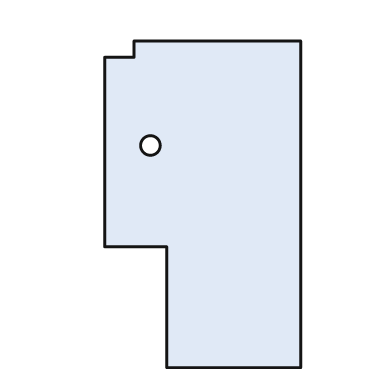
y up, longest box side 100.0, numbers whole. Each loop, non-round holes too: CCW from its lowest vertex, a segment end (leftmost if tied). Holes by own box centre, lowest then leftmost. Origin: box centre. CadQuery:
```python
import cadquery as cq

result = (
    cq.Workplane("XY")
    .moveTo(-11.0, -50.0)
    .lineTo(30.0, -50.0)
    .lineTo(30.0, 50.0)
    .lineTo(-21.0, 50.0)
    .lineTo(-21.0, 45.0)
    .lineTo(-30.0, 45.0)
    .lineTo(-30.0, -13.0)
    .lineTo(-11.0, -13.0)
    .close()
    .moveTo(-16.0, 18.0)
    .circle(3.0)
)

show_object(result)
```